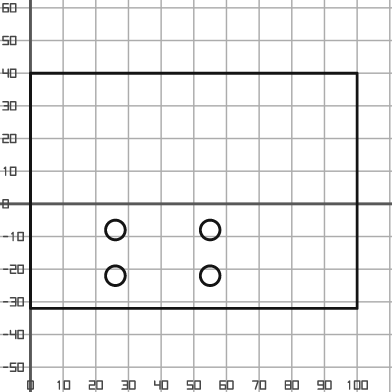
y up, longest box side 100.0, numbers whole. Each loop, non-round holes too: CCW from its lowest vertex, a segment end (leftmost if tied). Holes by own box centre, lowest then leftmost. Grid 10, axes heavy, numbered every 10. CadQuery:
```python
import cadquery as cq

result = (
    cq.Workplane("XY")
    .moveTo(0.0, -32.0)
    .lineTo(100.0, -32.0)
    .lineTo(100.0, 40.0)
    .lineTo(0.0, 40.0)
    .close()
    .moveTo(26.0, -22.0)
    .circle(3.0)
    .moveTo(55.0, -22.0)
    .circle(3.0)
    .moveTo(26.0, -8.0)
    .circle(3.0)
    .moveTo(55.0, -8.0)
    .circle(3.0)
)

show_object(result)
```